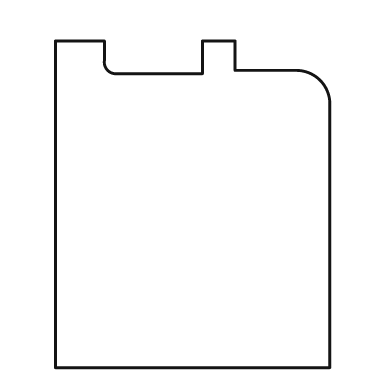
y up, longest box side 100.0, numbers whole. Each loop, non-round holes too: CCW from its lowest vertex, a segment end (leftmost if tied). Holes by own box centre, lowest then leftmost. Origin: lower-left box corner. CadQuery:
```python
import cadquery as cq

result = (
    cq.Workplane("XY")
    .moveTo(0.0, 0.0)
    .lineTo(84.0, 0.0)
    .lineTo(84.0, 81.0)
    .threePointArc((81.0, 88.0), (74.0, 91.0))
    .lineTo(55.0, 91.0)
    .lineTo(55.0, 100.0)
    .lineTo(45.0, 100.0)
    .lineTo(45.0, 90.0)
    .lineTo(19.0, 90.0)
    .threePointArc((16.0, 91.0), (15.0, 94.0))
    .lineTo(15.0, 100.0)
    .lineTo(0.0, 100.0)
    .close()
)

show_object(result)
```